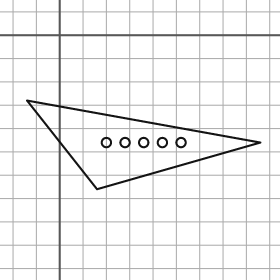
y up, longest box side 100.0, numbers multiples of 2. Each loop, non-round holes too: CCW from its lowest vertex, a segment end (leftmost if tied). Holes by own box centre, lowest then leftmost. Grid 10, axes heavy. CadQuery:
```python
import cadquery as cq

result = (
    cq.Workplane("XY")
    .moveTo(16.0, -66.0)
    .lineTo(86.0, -46.0)
    .lineTo(-14.0, -28.0)
    .close()
    .moveTo(20.0, -46.0)
    .circle(2.0)
    .moveTo(28.0, -46.0)
    .circle(2.0)
    .moveTo(36.0, -46.0)
    .circle(2.0)
    .moveTo(44.0, -46.0)
    .circle(2.0)
    .moveTo(52.0, -46.0)
    .circle(2.0)
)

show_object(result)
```